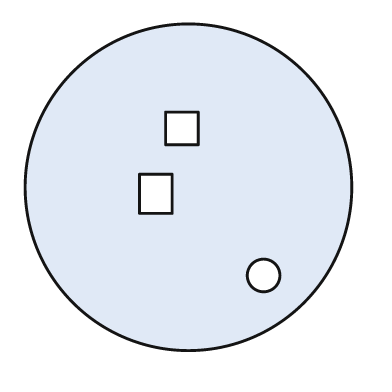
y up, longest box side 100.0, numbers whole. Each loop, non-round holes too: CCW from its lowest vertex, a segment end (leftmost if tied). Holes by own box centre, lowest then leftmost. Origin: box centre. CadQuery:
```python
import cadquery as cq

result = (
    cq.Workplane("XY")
    .moveTo(0.0, 0.0)
    .circle(50.0)
    .moveTo(23.0, -27.0)
    .circle(5.0)
    .moveTo(-15.0, -8.0)
    .lineTo(-5.0, -8.0)
    .lineTo(-5.0, 4.0)
    .lineTo(-15.0, 4.0)
    .close()
    .moveTo(-7.0, 13.0)
    .lineTo(3.0, 13.0)
    .lineTo(3.0, 23.0)
    .lineTo(-7.0, 23.0)
    .close()
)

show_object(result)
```